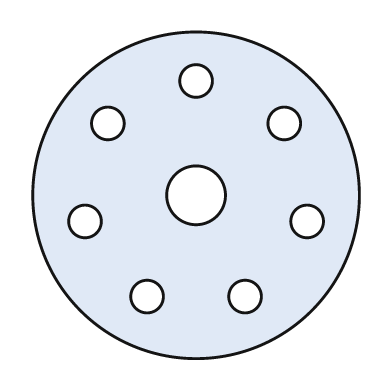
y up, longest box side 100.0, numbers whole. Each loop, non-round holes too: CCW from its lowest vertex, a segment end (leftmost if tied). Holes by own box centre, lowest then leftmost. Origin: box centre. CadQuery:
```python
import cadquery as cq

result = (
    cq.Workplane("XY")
    .moveTo(0.0, 0.0)
    .circle(50.0)
    .moveTo(-15.0, -31.0)
    .circle(5.0)
    .moveTo(15.0, -31.0)
    .circle(5.0)
    .moveTo(-34.0, -8.0)
    .circle(5.0)
    .moveTo(34.0, -8.0)
    .circle(5.0)
    .moveTo(0.0, 0.0)
    .circle(9.0)
    .moveTo(-27.0, 22.0)
    .circle(5.0)
    .moveTo(27.0, 22.0)
    .circle(5.0)
    .moveTo(0.0, 35.0)
    .circle(5.0)
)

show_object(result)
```